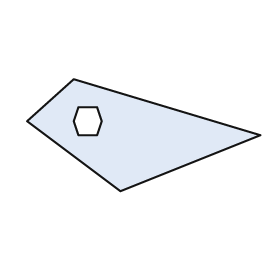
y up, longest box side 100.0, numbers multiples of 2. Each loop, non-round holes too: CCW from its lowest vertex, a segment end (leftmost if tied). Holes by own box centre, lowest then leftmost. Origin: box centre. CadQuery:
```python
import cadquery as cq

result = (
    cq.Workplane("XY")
    .moveTo(-10.0, -24.0)
    .lineTo(50.0, 0.0)
    .lineTo(-30.0, 24.0)
    .lineTo(-50.0, 6.0)
    .close()
    .moveTo(-28.0, 0.0)
    .lineTo(-20.0, 0.0)
    .lineTo(-18.0, 6.0)
    .lineTo(-20.0, 12.0)
    .lineTo(-28.0, 12.0)
    .lineTo(-30.0, 6.0)
    .close()
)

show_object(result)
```